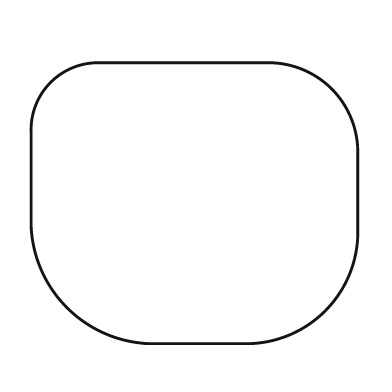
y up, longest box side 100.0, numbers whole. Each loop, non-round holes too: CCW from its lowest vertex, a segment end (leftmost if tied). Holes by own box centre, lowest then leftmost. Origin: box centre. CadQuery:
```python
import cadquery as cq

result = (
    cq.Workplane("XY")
    .moveTo(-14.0, -43.0)
    .lineTo(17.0, -43.0)
    .threePointArc((40.0, -33.0), (50.0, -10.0))
    .lineTo(50.0, 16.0)
    .threePointArc((42.0, 35.0), (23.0, 43.0))
    .lineTo(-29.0, 43.0)
    .threePointArc((-44.0, 37.0), (-50.0, 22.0))
    .lineTo(-50.0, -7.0)
    .threePointArc((-39.0, -32.0), (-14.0, -43.0))
    .close()
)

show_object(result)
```